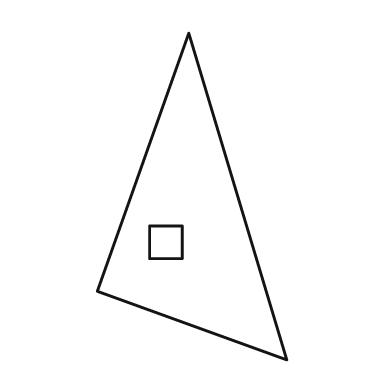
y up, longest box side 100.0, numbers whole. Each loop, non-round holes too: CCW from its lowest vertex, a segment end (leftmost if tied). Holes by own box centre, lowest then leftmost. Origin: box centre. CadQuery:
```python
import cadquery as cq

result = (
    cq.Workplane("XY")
    .moveTo(29.0, -50.0)
    .lineTo(-1.0, 50.0)
    .lineTo(-29.0, -29.0)
    .close()
    .moveTo(-13.0, -19.0)
    .lineTo(-3.0, -19.0)
    .lineTo(-3.0, -9.0)
    .lineTo(-13.0, -9.0)
    .close()
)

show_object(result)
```